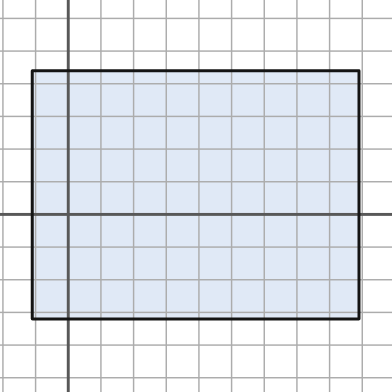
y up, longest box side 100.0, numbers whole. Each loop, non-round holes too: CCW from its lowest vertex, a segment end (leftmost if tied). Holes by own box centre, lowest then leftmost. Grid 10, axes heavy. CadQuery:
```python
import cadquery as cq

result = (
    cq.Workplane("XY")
    .moveTo(-11.0, -32.0)
    .lineTo(89.0, -32.0)
    .lineTo(89.0, 44.0)
    .lineTo(-11.0, 44.0)
    .close()
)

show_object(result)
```